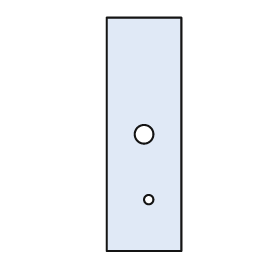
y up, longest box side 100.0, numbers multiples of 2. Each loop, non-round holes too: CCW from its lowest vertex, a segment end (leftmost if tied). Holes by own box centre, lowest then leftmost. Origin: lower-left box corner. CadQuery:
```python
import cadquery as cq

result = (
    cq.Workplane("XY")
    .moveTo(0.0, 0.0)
    .lineTo(32.0, 0.0)
    .lineTo(32.0, 100.0)
    .lineTo(0.0, 100.0)
    .close()
    .moveTo(18.0, 22.0)
    .circle(2.0)
    .moveTo(16.0, 50.0)
    .circle(4.0)
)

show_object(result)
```